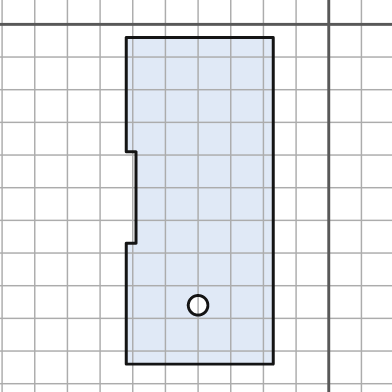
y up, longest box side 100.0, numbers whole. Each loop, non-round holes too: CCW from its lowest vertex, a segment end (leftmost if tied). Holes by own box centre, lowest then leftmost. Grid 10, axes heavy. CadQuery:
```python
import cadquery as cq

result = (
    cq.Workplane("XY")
    .moveTo(-62.0, -104.0)
    .lineTo(-17.0, -104.0)
    .lineTo(-17.0, -4.0)
    .lineTo(-62.0, -4.0)
    .lineTo(-62.0, -39.0)
    .lineTo(-59.0, -39.0)
    .lineTo(-59.0, -67.0)
    .lineTo(-62.0, -67.0)
    .close()
    .moveTo(-40.0, -86.0)
    .circle(3.0)
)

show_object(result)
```